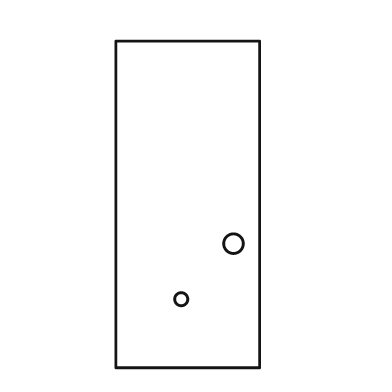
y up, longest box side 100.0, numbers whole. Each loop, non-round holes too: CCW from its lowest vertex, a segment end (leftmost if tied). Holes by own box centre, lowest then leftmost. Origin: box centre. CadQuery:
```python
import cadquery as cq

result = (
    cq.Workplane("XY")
    .moveTo(-22.0, -50.0)
    .lineTo(22.0, -50.0)
    .lineTo(22.0, 50.0)
    .lineTo(-22.0, 50.0)
    .close()
    .moveTo(-2.0, -29.0)
    .circle(2.0)
    .moveTo(14.0, -12.0)
    .circle(3.0)
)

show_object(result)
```